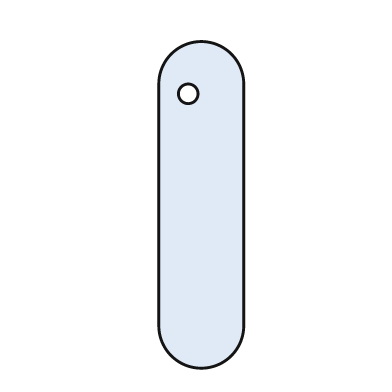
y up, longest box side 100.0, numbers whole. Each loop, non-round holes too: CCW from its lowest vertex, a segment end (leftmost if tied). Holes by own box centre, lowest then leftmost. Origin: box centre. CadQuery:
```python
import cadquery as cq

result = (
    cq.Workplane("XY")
    .moveTo(-13.0, -37.0)
    .threePointArc((0.0, -50.0), (13.0, -37.0))
    .lineTo(13.0, 37.0)
    .threePointArc((0.0, 50.0), (-13.0, 37.0))
    .close()
    .moveTo(-4.0, 34.0)
    .circle(3.0)
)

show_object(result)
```